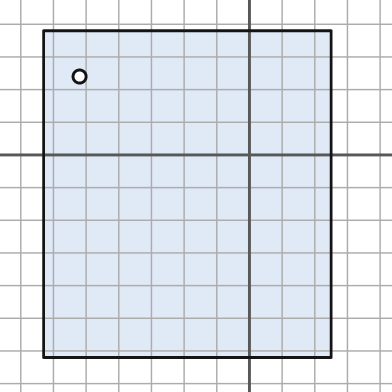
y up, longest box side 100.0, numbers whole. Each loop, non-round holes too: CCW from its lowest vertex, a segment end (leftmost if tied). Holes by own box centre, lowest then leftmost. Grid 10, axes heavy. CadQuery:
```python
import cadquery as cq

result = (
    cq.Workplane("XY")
    .moveTo(-63.0, -62.0)
    .lineTo(25.0, -62.0)
    .lineTo(25.0, 38.0)
    .lineTo(-63.0, 38.0)
    .close()
    .moveTo(-52.0, 24.0)
    .circle(2.0)
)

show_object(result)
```